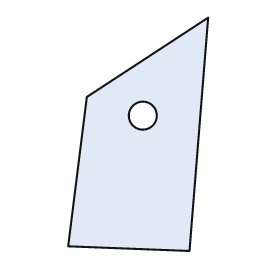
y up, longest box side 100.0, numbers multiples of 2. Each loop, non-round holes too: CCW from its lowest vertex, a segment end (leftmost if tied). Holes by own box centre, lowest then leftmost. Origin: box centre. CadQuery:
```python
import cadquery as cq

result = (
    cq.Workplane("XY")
    .moveTo(22.0, -50.0)
    .lineTo(30.0, 50.0)
    .lineTo(-22.0, 16.0)
    .lineTo(-30.0, -48.0)
    .close()
    .moveTo(2.0, 8.0)
    .circle(6.0)
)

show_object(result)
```